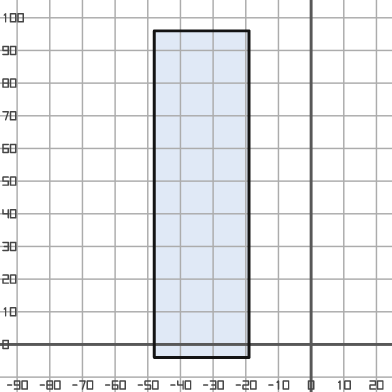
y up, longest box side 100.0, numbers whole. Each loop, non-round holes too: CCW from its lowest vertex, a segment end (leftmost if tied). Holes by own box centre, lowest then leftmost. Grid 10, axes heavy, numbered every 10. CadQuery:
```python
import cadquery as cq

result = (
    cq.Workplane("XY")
    .moveTo(-48.0, -4.0)
    .lineTo(-19.0, -4.0)
    .lineTo(-19.0, 96.0)
    .lineTo(-48.0, 96.0)
    .close()
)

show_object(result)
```